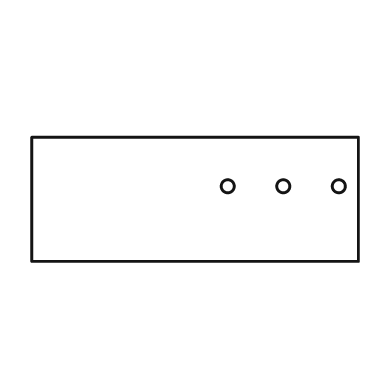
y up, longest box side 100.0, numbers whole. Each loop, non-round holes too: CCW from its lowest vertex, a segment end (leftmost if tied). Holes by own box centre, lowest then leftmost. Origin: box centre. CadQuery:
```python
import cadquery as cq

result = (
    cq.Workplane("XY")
    .moveTo(-50.0, -19.0)
    .lineTo(50.0, -19.0)
    .lineTo(50.0, 19.0)
    .lineTo(-50.0, 19.0)
    .close()
    .moveTo(10.0, 4.0)
    .circle(2.0)
    .moveTo(27.0, 4.0)
    .circle(2.0)
    .moveTo(44.0, 4.0)
    .circle(2.0)
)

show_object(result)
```